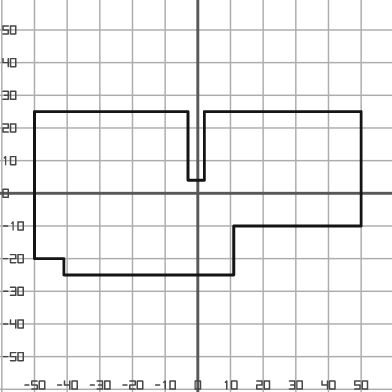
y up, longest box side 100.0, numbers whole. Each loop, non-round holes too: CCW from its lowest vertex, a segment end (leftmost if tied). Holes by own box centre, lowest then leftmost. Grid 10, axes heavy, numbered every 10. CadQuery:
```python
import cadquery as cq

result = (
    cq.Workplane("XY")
    .moveTo(-41.0, -25.0)
    .lineTo(11.0, -25.0)
    .lineTo(11.0, -10.0)
    .lineTo(50.0, -10.0)
    .lineTo(50.0, 25.0)
    .lineTo(2.0, 25.0)
    .lineTo(2.0, 4.0)
    .lineTo(-3.0, 4.0)
    .lineTo(-3.0, 25.0)
    .lineTo(-50.0, 25.0)
    .lineTo(-50.0, -20.0)
    .lineTo(-41.0, -20.0)
    .close()
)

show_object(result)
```